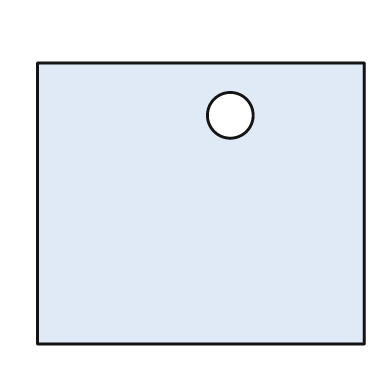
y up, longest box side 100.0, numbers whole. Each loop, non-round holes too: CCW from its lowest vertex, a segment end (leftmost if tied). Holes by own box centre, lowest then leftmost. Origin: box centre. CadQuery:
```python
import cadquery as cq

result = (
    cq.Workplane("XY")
    .moveTo(-50.0, -43.0)
    .lineTo(50.0, -43.0)
    .lineTo(50.0, 43.0)
    .lineTo(-50.0, 43.0)
    .close()
    .moveTo(9.0, 27.0)
    .circle(7.0)
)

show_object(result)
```